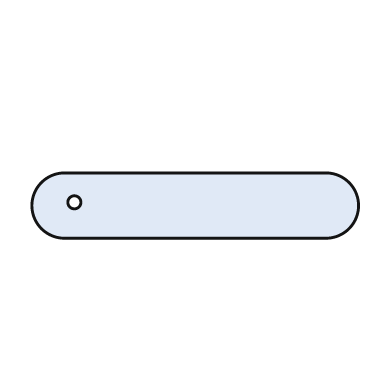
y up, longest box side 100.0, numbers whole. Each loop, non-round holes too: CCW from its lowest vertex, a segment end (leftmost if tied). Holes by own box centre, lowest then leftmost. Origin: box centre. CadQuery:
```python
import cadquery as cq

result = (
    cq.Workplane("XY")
    .moveTo(-40.0, -10.0)
    .lineTo(40.0, -10.0)
    .threePointArc((50.0, 0.0), (40.0, 10.0))
    .lineTo(-40.0, 10.0)
    .threePointArc((-50.0, 0.0), (-40.0, -10.0))
    .close()
    .moveTo(-37.0, 1.0)
    .circle(2.0)
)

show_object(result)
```